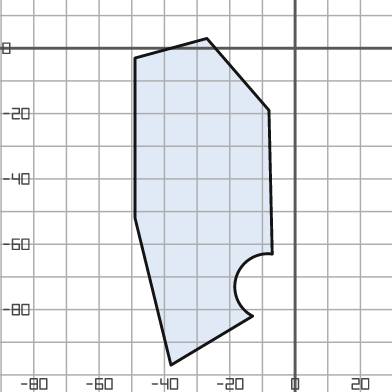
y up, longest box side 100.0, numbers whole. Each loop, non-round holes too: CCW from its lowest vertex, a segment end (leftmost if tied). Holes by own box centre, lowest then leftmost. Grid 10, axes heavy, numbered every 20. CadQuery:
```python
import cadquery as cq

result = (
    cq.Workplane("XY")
    .moveTo(-38.0, -97.0)
    .lineTo(-13.0, -82.0)
    .threePointArc((-18.0, -70.0), (-7.0, -63.0))
    .lineTo(-8.0, -19.0)
    .lineTo(-27.0, 3.0)
    .lineTo(-49.0, -3.0)
    .lineTo(-49.0, -52.0)
    .close()
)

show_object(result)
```